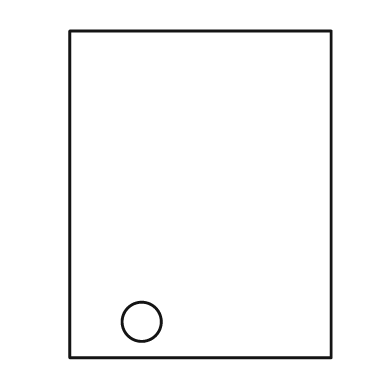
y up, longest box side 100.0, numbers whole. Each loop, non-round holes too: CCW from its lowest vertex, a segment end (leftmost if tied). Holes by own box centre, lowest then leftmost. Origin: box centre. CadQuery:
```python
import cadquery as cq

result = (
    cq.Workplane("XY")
    .moveTo(-40.0, -50.0)
    .lineTo(40.0, -50.0)
    .lineTo(40.0, 50.0)
    .lineTo(-40.0, 50.0)
    .close()
    .moveTo(-18.0, -39.0)
    .circle(6.0)
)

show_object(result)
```